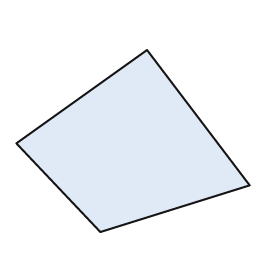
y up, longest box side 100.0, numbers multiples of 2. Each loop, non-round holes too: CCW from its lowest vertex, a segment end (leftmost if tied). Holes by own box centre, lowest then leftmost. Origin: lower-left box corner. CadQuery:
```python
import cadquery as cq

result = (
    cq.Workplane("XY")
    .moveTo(36.0, 0.0)
    .lineTo(100.0, 20.0)
    .lineTo(56.0, 78.0)
    .lineTo(0.0, 38.0)
    .close()
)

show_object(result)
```